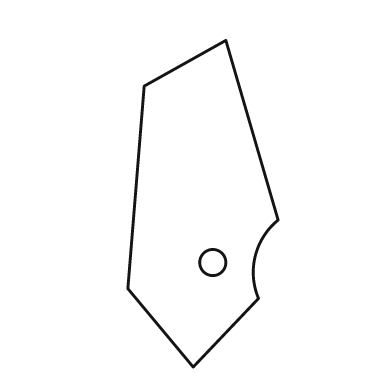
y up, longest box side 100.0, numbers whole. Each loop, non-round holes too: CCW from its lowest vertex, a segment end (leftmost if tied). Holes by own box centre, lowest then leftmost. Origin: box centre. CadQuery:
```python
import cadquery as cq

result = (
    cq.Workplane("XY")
    .moveTo(-3.0, -50.0)
    .lineTo(17.0, -29.0)
    .threePointArc((16.0, -16.0), (23.0, -5.0))
    .lineTo(7.0, 50.0)
    .lineTo(-18.0, 36.0)
    .lineTo(-23.0, -26.0)
    .close()
    .moveTo(3.0, -18.0)
    .circle(4.0)
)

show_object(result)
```